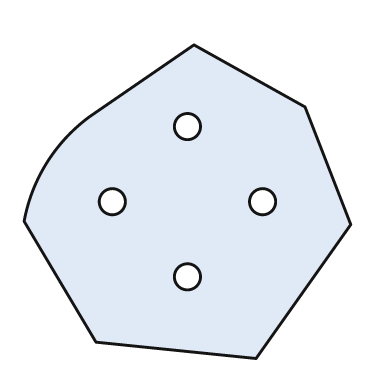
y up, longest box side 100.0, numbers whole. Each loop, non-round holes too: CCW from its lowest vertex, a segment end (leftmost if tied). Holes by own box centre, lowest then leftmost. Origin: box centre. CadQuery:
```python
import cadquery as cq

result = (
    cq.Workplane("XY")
    .moveTo(21.0, -48.0)
    .lineTo(50.0, -7.0)
    .lineTo(36.0, 29.0)
    .lineTo(2.0, 48.0)
    .lineTo(-30.0, 26.0)
    .threePointArc((-43.0, 12.0), (-50.0, -6.0))
    .lineTo(-28.0, -43.0)
    .close()
    .moveTo(0.0, -23.0)
    .circle(4.0)
    .moveTo(-23.0, 0.0)
    .circle(4.0)
    .moveTo(23.0, 0.0)
    .circle(4.0)
    .moveTo(0.0, 23.0)
    .circle(4.0)
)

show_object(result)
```